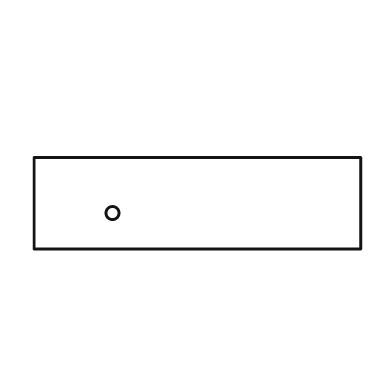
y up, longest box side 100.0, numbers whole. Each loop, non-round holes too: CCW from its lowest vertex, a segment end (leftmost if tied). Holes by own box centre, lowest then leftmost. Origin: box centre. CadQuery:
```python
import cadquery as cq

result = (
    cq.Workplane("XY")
    .moveTo(-50.0, -14.0)
    .lineTo(50.0, -14.0)
    .lineTo(50.0, 14.0)
    .lineTo(-50.0, 14.0)
    .close()
    .moveTo(-26.0, -3.0)
    .circle(2.0)
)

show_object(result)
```